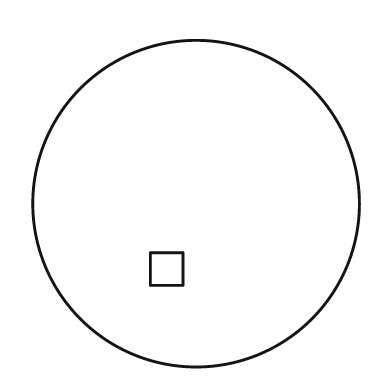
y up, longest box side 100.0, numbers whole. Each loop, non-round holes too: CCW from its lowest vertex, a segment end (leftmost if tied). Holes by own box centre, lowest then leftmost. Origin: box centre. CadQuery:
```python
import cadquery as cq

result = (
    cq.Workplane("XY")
    .moveTo(0.0, 0.0)
    .circle(50.0)
    .moveTo(-14.0, -25.0)
    .lineTo(-4.0, -25.0)
    .lineTo(-4.0, -15.0)
    .lineTo(-14.0, -15.0)
    .close()
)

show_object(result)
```